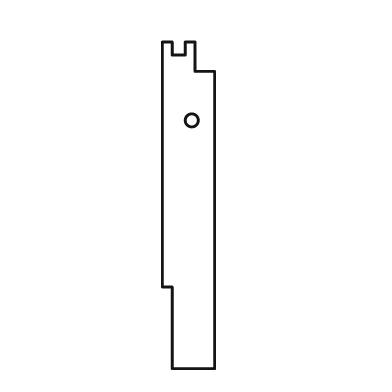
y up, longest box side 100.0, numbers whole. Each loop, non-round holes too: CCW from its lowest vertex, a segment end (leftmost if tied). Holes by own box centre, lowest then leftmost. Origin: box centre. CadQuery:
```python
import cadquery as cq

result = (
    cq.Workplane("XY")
    .moveTo(-5.0, -50.0)
    .lineTo(8.0, -50.0)
    .lineTo(8.0, 41.0)
    .lineTo(2.0, 41.0)
    .lineTo(2.0, 50.0)
    .lineTo(-1.0, 50.0)
    .lineTo(-1.0, 46.0)
    .lineTo(-5.0, 46.0)
    .lineTo(-5.0, 50.0)
    .lineTo(-8.0, 50.0)
    .lineTo(-8.0, -25.0)
    .lineTo(-5.0, -25.0)
    .close()
    .moveTo(1.0, 26.0)
    .circle(2.0)
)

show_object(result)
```